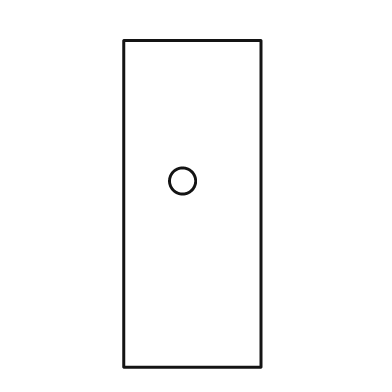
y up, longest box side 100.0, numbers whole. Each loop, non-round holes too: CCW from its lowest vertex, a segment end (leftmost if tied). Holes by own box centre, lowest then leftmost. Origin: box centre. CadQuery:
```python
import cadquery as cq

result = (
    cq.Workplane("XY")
    .moveTo(-21.0, -50.0)
    .lineTo(21.0, -50.0)
    .lineTo(21.0, 50.0)
    .lineTo(-21.0, 50.0)
    .close()
    .moveTo(-3.0, 7.0)
    .circle(4.0)
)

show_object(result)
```